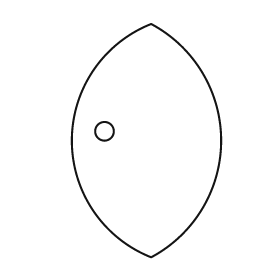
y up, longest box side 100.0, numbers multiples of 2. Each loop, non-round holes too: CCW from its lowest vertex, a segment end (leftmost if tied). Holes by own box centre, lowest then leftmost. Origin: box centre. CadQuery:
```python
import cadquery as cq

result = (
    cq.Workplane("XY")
    .moveTo(2.0, -50.0)
    .threePointArc((32.0, 0.0), (2.0, 50.0))
    .threePointArc((-32.0, 0.0), (2.0, -50.0))
    .close()
    .moveTo(-18.0, 4.0)
    .circle(4.0)
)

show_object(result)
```